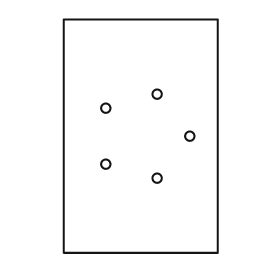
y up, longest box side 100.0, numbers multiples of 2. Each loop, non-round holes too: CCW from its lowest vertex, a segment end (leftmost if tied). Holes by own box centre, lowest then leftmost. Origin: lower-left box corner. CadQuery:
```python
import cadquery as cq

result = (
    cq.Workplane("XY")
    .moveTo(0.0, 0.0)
    .lineTo(66.0, 0.0)
    .lineTo(66.0, 100.0)
    .lineTo(0.0, 100.0)
    .close()
    .moveTo(40.0, 32.0)
    .circle(2.0)
    .moveTo(18.0, 38.0)
    .circle(2.0)
    .moveTo(54.0, 50.0)
    .circle(2.0)
    .moveTo(18.0, 62.0)
    .circle(2.0)
    .moveTo(40.0, 68.0)
    .circle(2.0)
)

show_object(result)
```